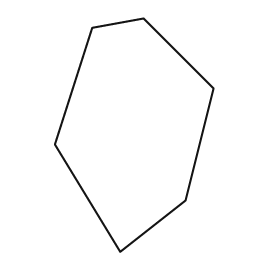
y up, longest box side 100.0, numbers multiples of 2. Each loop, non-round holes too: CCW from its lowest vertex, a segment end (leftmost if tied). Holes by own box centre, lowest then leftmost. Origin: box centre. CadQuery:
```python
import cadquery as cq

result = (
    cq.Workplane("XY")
    .moveTo(-6.0, -50.0)
    .lineTo(22.0, -28.0)
    .lineTo(34.0, 20.0)
    .lineTo(4.0, 50.0)
    .lineTo(-18.0, 46.0)
    .lineTo(-34.0, -4.0)
    .close()
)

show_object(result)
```